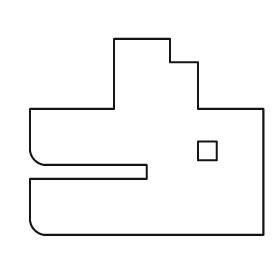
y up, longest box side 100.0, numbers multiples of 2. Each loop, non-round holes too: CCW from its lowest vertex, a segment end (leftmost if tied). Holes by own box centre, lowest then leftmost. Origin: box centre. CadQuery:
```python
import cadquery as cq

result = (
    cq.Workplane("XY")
    .moveTo(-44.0, -42.0)
    .lineTo(50.0, -42.0)
    .lineTo(50.0, 12.0)
    .lineTo(22.0, 12.0)
    .lineTo(22.0, 32.0)
    .lineTo(10.0, 32.0)
    .lineTo(10.0, 42.0)
    .lineTo(-14.0, 42.0)
    .lineTo(-14.0, 12.0)
    .lineTo(-50.0, 12.0)
    .lineTo(-50.0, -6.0)
    .threePointArc((-48.0, -10.0), (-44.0, -12.0))
    .lineTo(0.0, -12.0)
    .lineTo(0.0, -18.0)
    .lineTo(-50.0, -18.0)
    .lineTo(-50.0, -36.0)
    .threePointArc((-48.0, -40.0), (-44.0, -42.0))
    .close()
    .moveTo(22.0, -10.0)
    .lineTo(30.0, -10.0)
    .lineTo(30.0, -2.0)
    .lineTo(22.0, -2.0)
    .close()
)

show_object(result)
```